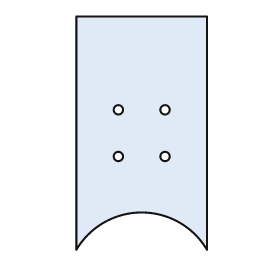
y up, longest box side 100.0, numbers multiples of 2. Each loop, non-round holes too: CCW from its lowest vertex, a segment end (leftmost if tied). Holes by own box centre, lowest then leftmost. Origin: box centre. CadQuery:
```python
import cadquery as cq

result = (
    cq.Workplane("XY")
    .moveTo(-28.0, -50.0)
    .threePointArc((0.0, -34.0), (28.0, -50.0))
    .lineTo(28.0, 50.0)
    .lineTo(-28.0, 50.0)
    .close()
    .moveTo(-10.0, -10.0)
    .circle(2.0)
    .moveTo(10.0, -10.0)
    .circle(2.0)
    .moveTo(-10.0, 10.0)
    .circle(2.0)
    .moveTo(10.0, 10.0)
    .circle(2.0)
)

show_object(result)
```